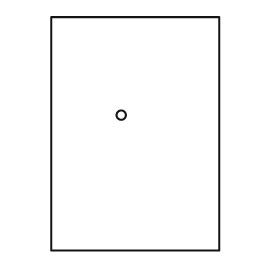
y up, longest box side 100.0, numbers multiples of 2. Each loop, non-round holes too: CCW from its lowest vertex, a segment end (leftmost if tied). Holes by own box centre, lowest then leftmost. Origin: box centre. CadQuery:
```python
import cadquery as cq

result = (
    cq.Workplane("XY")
    .moveTo(-36.0, -50.0)
    .lineTo(36.0, -50.0)
    .lineTo(36.0, 50.0)
    .lineTo(-36.0, 50.0)
    .close()
    .moveTo(-6.0, 8.0)
    .circle(2.0)
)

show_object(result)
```